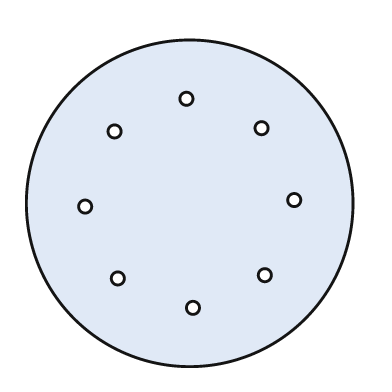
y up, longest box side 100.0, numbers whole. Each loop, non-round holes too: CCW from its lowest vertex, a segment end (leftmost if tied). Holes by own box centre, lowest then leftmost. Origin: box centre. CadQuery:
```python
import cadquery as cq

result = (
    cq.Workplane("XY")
    .moveTo(0.0, 0.0)
    .circle(50.0)
    .moveTo(1.0, -32.0)
    .circle(2.0)
    .moveTo(-22.0, -23.0)
    .circle(2.0)
    .moveTo(23.0, -22.0)
    .circle(2.0)
    .moveTo(-32.0, -1.0)
    .circle(2.0)
    .moveTo(32.0, 1.0)
    .circle(2.0)
    .moveTo(-23.0, 22.0)
    .circle(2.0)
    .moveTo(22.0, 23.0)
    .circle(2.0)
    .moveTo(-1.0, 32.0)
    .circle(2.0)
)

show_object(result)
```